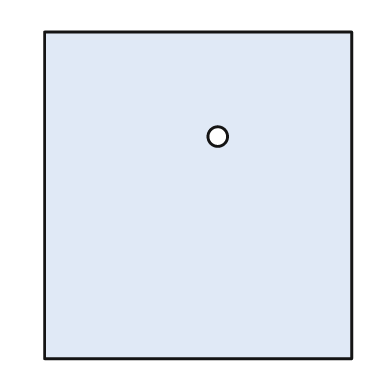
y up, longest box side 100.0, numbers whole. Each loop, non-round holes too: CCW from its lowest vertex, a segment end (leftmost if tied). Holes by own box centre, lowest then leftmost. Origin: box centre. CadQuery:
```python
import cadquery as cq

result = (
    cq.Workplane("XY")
    .moveTo(-47.0, -50.0)
    .lineTo(47.0, -50.0)
    .lineTo(47.0, 50.0)
    .lineTo(-47.0, 50.0)
    .close()
    .moveTo(6.0, 18.0)
    .circle(3.0)
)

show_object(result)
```